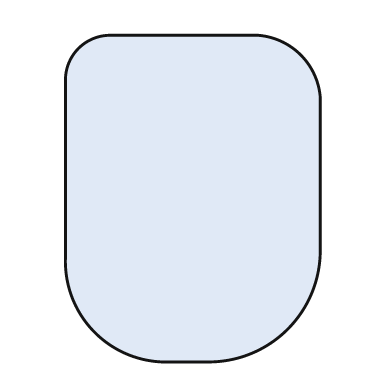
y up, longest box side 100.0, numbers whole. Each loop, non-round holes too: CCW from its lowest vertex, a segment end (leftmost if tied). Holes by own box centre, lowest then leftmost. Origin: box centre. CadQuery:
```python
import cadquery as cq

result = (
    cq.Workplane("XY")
    .moveTo(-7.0, -50.0)
    .lineTo(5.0, -50.0)
    .threePointArc((29.0, -40.0), (39.0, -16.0))
    .lineTo(39.0, 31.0)
    .threePointArc((33.0, 44.0), (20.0, 50.0))
    .lineTo(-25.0, 50.0)
    .threePointArc((-35.0, 46.0), (-39.0, 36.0))
    .lineTo(-39.0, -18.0)
    .threePointArc((-30.0, -41.0), (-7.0, -50.0))
    .close()
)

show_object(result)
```